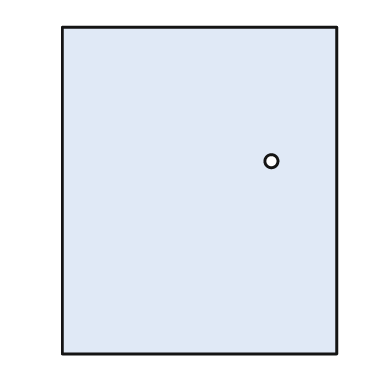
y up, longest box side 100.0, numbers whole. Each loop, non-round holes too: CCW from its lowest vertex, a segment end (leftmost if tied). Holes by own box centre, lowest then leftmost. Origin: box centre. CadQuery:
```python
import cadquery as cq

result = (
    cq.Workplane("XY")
    .moveTo(-42.0, -50.0)
    .lineTo(42.0, -50.0)
    .lineTo(42.0, 50.0)
    .lineTo(-42.0, 50.0)
    .close()
    .moveTo(22.0, 9.0)
    .circle(2.0)
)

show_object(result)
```